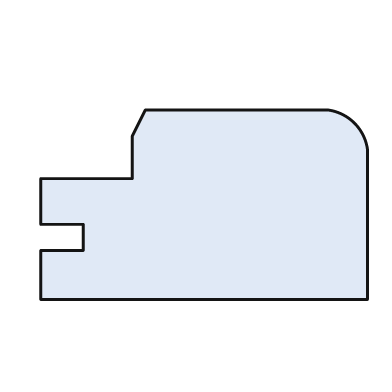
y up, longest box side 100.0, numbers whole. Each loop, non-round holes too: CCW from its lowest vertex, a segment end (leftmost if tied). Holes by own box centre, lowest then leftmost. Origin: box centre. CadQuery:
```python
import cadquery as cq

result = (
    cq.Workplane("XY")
    .moveTo(-50.0, -29.0)
    .lineTo(50.0, -29.0)
    .lineTo(50.0, 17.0)
    .threePointArc((46.0, 25.0), (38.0, 29.0))
    .lineTo(-18.0, 29.0)
    .lineTo(-22.0, 21.0)
    .lineTo(-22.0, 8.0)
    .lineTo(-50.0, 8.0)
    .lineTo(-50.0, -6.0)
    .lineTo(-37.0, -6.0)
    .lineTo(-37.0, -14.0)
    .lineTo(-50.0, -14.0)
    .close()
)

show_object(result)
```